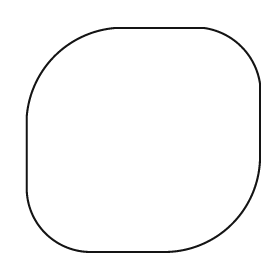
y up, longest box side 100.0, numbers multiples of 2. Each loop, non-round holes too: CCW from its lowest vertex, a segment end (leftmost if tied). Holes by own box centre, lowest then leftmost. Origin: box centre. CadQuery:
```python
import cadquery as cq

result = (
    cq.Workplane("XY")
    .moveTo(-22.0, -48.0)
    .lineTo(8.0, -48.0)
    .threePointArc((38.0, -36.0), (50.0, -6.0))
    .lineTo(50.0, 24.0)
    .threePointArc((42.0, 40.0), (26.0, 48.0))
    .lineTo(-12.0, 48.0)
    .threePointArc((-38.0, 36.0), (-50.0, 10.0))
    .lineTo(-50.0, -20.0)
    .threePointArc((-42.0, -40.0), (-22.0, -48.0))
    .close()
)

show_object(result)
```